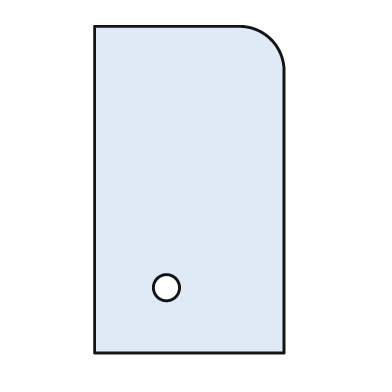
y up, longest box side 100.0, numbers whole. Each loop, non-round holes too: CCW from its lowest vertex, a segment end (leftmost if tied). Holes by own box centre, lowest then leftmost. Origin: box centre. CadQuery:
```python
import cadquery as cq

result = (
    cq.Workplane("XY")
    .moveTo(-29.0, -50.0)
    .lineTo(29.0, -50.0)
    .lineTo(29.0, 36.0)
    .threePointArc((25.0, 46.0), (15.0, 50.0))
    .lineTo(-29.0, 50.0)
    .close()
    .moveTo(-7.0, -30.0)
    .circle(4.0)
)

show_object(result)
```